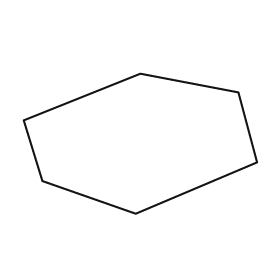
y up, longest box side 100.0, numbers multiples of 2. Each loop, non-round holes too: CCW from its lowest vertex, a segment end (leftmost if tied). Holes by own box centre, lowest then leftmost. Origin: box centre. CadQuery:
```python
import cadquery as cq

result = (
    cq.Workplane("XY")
    .moveTo(-2.0, -30.0)
    .lineTo(50.0, -8.0)
    .lineTo(42.0, 22.0)
    .lineTo(0.0, 30.0)
    .lineTo(-50.0, 10.0)
    .lineTo(-42.0, -16.0)
    .close()
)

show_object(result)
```